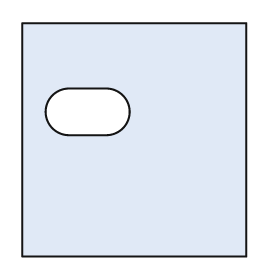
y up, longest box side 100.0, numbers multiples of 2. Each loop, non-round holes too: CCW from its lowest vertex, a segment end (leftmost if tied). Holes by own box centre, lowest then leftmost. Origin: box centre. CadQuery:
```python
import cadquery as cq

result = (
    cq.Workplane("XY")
    .moveTo(-48.0, -50.0)
    .lineTo(48.0, -50.0)
    .lineTo(48.0, 50.0)
    .lineTo(-48.0, 50.0)
    .close()
    .moveTo(-28.0, 2.0)
    .lineTo(-12.0, 2.0)
    .threePointArc((-2.0, 12.0), (-12.0, 22.0))
    .lineTo(-28.0, 22.0)
    .threePointArc((-38.0, 12.0), (-28.0, 2.0))
    .close()
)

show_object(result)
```